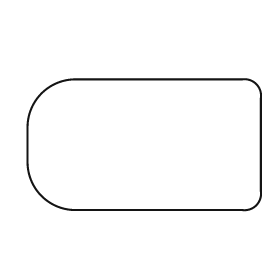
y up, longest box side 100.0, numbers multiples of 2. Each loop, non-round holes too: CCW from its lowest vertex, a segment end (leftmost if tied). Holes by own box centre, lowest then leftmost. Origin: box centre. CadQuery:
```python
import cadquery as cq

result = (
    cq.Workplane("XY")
    .moveTo(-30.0, -28.0)
    .lineTo(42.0, -28.0)
    .threePointArc((48.0, -26.0), (50.0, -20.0))
    .lineTo(50.0, 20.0)
    .threePointArc((48.0, 26.0), (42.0, 28.0))
    .lineTo(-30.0, 28.0)
    .threePointArc((-44.0, 22.0), (-50.0, 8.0))
    .lineTo(-50.0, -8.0)
    .threePointArc((-44.0, -22.0), (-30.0, -28.0))
    .close()
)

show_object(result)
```